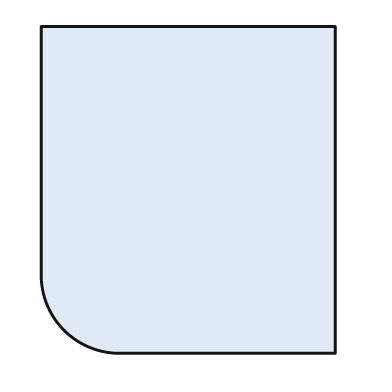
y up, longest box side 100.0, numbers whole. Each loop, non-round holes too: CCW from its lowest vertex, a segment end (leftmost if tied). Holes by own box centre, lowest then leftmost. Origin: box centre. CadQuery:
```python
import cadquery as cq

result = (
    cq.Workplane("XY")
    .moveTo(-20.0, -50.0)
    .lineTo(45.0, -50.0)
    .lineTo(45.0, 50.0)
    .lineTo(-45.0, 50.0)
    .lineTo(-45.0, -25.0)
    .threePointArc((-38.0, -43.0), (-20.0, -50.0))
    .close()
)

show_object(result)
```